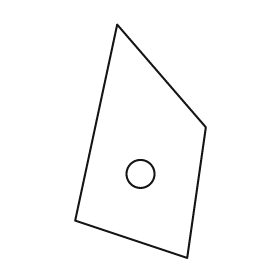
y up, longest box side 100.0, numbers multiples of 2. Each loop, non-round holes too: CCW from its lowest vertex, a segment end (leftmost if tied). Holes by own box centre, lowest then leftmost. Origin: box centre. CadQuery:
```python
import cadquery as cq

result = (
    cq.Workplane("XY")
    .moveTo(20.0, -50.0)
    .lineTo(28.0, 6.0)
    .lineTo(-10.0, 50.0)
    .lineTo(-28.0, -34.0)
    .close()
    .moveTo(0.0, -14.0)
    .circle(6.0)
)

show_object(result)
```